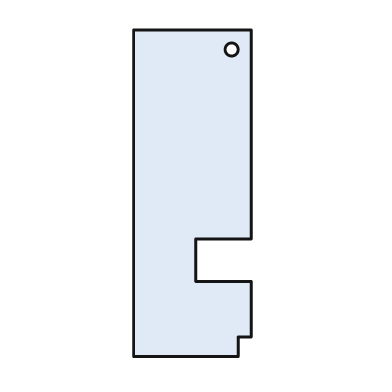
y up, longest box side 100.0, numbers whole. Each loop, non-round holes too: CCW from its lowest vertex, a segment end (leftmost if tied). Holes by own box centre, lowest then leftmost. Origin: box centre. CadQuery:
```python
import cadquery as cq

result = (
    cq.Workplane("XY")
    .moveTo(-18.0, -50.0)
    .lineTo(14.0, -50.0)
    .lineTo(14.0, -44.0)
    .lineTo(18.0, -44.0)
    .lineTo(18.0, -27.0)
    .lineTo(1.0, -27.0)
    .lineTo(1.0, -14.0)
    .lineTo(18.0, -14.0)
    .lineTo(18.0, 50.0)
    .lineTo(-18.0, 50.0)
    .close()
    .moveTo(12.0, 44.0)
    .circle(2.0)
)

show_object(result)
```